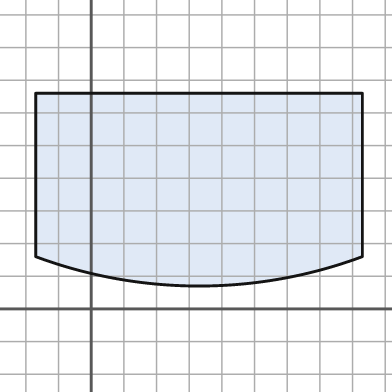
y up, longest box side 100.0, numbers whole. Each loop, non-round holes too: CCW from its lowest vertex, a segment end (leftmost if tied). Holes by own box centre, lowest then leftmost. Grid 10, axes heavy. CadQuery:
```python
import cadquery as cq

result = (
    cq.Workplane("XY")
    .moveTo(-17.0, 16.0)
    .threePointArc((33.0, 7.0), (83.0, 16.0))
    .lineTo(83.0, 66.0)
    .lineTo(-17.0, 66.0)
    .close()
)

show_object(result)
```